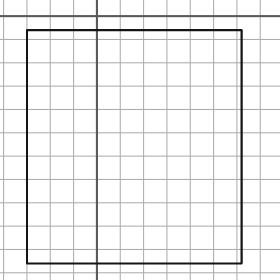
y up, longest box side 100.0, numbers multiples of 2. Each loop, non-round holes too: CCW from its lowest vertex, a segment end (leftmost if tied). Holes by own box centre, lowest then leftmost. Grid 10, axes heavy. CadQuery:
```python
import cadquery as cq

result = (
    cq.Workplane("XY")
    .moveTo(-30.0, -106.0)
    .lineTo(62.0, -106.0)
    .lineTo(62.0, -6.0)
    .lineTo(-30.0, -6.0)
    .close()
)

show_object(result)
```